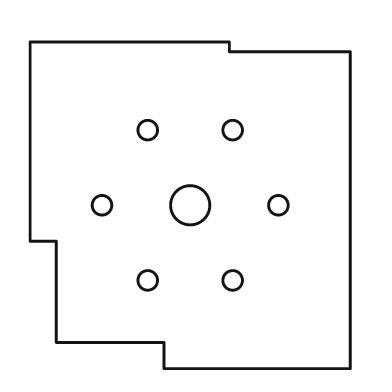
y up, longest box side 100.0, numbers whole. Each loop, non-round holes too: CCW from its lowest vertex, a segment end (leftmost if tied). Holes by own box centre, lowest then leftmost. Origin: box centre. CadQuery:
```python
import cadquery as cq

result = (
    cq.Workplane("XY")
    .moveTo(-8.0, -50.0)
    .lineTo(49.0, -50.0)
    .lineTo(49.0, 47.0)
    .lineTo(12.0, 47.0)
    .lineTo(12.0, 50.0)
    .lineTo(-49.0, 50.0)
    .lineTo(-49.0, -11.0)
    .lineTo(-41.0, -11.0)
    .lineTo(-41.0, -42.0)
    .lineTo(-8.0, -42.0)
    .close()
    .moveTo(-13.0, -23.0)
    .circle(3.0)
    .moveTo(13.0, -23.0)
    .circle(3.0)
    .moveTo(-27.0, 0.0)
    .circle(3.0)
    .moveTo(0.0, 0.0)
    .circle(6.0)
    .moveTo(27.0, 0.0)
    .circle(3.0)
    .moveTo(-13.0, 23.0)
    .circle(3.0)
    .moveTo(13.0, 23.0)
    .circle(3.0)
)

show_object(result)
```